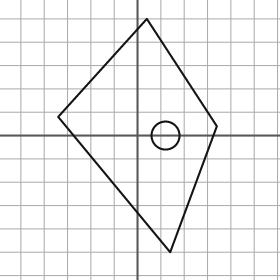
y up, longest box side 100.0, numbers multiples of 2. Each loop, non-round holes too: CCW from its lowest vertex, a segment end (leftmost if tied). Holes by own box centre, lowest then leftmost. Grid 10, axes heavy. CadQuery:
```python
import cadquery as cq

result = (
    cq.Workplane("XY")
    .moveTo(14.0, -50.0)
    .lineTo(34.0, 4.0)
    .lineTo(4.0, 50.0)
    .lineTo(-34.0, 8.0)
    .close()
    .moveTo(12.0, 0.0)
    .circle(6.0)
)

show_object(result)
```